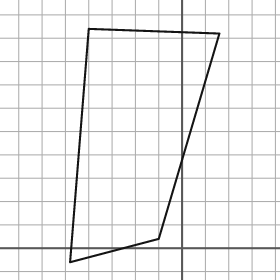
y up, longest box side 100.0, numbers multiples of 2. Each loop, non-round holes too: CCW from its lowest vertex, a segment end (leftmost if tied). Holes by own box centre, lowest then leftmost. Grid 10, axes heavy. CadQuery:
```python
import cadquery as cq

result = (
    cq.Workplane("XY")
    .moveTo(-48.0, -6.0)
    .lineTo(-10.0, 4.0)
    .lineTo(16.0, 92.0)
    .lineTo(-40.0, 94.0)
    .close()
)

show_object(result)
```